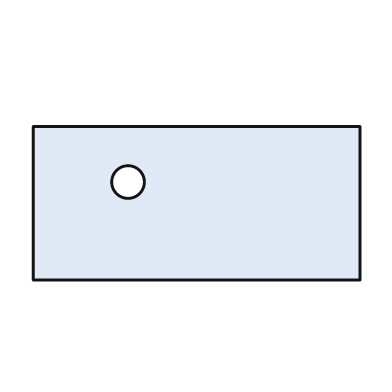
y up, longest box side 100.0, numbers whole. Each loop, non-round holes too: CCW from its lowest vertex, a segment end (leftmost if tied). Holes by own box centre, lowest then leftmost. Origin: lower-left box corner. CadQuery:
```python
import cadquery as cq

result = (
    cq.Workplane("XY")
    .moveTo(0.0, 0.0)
    .lineTo(100.0, 0.0)
    .lineTo(100.0, 47.0)
    .lineTo(0.0, 47.0)
    .close()
    .moveTo(29.0, 30.0)
    .circle(5.0)
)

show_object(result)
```